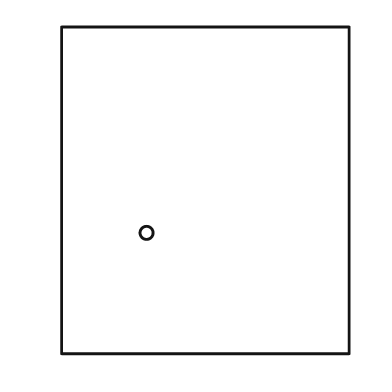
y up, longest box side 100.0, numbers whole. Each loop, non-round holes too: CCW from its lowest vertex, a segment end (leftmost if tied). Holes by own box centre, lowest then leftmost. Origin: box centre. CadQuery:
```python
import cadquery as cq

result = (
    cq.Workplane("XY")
    .moveTo(-44.0, -50.0)
    .lineTo(44.0, -50.0)
    .lineTo(44.0, 50.0)
    .lineTo(-44.0, 50.0)
    .close()
    .moveTo(-18.0, -13.0)
    .circle(2.0)
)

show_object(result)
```